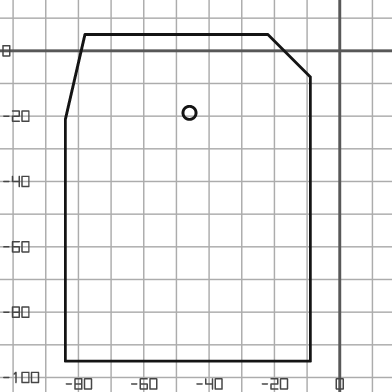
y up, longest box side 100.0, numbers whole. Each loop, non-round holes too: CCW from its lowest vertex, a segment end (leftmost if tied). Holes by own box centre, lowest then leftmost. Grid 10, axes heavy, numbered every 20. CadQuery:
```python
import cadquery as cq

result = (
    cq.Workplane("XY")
    .moveTo(-84.0, -95.0)
    .lineTo(-9.0, -95.0)
    .lineTo(-9.0, -8.0)
    .lineTo(-22.0, 5.0)
    .lineTo(-78.0, 5.0)
    .lineTo(-84.0, -21.0)
    .close()
    .moveTo(-46.0, -19.0)
    .circle(2.0)
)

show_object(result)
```